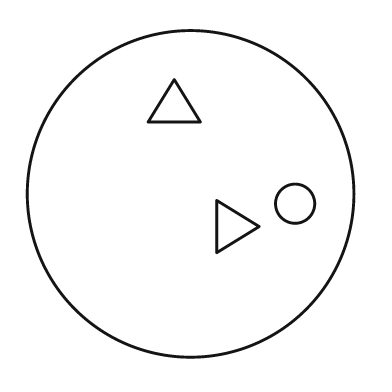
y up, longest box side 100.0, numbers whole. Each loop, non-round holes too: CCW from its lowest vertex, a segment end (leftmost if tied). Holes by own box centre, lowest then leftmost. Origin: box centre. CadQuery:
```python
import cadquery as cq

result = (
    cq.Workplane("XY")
    .moveTo(0.0, 0.0)
    .circle(50.0)
    .moveTo(8.0, -18.0)
    .lineTo(21.0, -10.0)
    .lineTo(8.0, -2.0)
    .close()
    .moveTo(32.0, -3.0)
    .circle(6.0)
    .moveTo(-13.0, 22.0)
    .lineTo(3.0, 22.0)
    .lineTo(-5.0, 35.0)
    .close()
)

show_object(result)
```